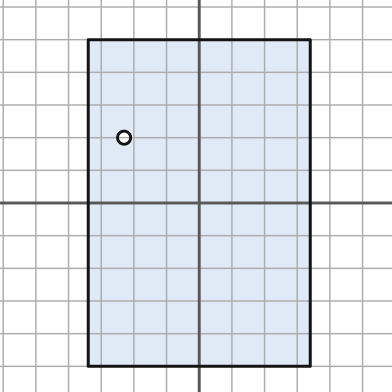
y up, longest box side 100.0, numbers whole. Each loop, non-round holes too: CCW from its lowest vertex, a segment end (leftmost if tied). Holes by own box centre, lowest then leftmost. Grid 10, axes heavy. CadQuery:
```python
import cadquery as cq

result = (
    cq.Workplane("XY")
    .moveTo(-34.0, -50.0)
    .lineTo(34.0, -50.0)
    .lineTo(34.0, 50.0)
    .lineTo(-34.0, 50.0)
    .close()
    .moveTo(-23.0, 20.0)
    .circle(2.0)
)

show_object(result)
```